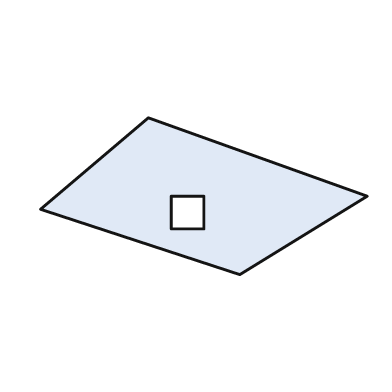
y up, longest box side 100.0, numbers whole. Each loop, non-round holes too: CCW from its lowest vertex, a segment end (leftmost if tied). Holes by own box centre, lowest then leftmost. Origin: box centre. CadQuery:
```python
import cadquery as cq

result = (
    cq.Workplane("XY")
    .moveTo(11.0, -24.0)
    .lineTo(50.0, 0.0)
    .lineTo(-17.0, 24.0)
    .lineTo(-50.0, -4.0)
    .close()
    .moveTo(-10.0, -10.0)
    .lineTo(0.0, -10.0)
    .lineTo(0.0, 0.0)
    .lineTo(-10.0, 0.0)
    .close()
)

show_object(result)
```